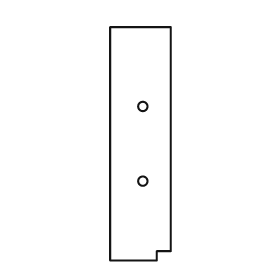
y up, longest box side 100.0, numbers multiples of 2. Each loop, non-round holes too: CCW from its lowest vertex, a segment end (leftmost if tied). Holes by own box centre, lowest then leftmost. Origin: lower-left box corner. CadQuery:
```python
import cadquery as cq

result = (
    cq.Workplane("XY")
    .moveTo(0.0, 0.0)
    .lineTo(20.0, 0.0)
    .lineTo(20.0, 4.0)
    .lineTo(26.0, 4.0)
    .lineTo(26.0, 100.0)
    .lineTo(0.0, 100.0)
    .close()
    .moveTo(14.0, 34.0)
    .circle(2.0)
    .moveTo(14.0, 66.0)
    .circle(2.0)
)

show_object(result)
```